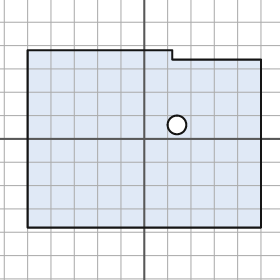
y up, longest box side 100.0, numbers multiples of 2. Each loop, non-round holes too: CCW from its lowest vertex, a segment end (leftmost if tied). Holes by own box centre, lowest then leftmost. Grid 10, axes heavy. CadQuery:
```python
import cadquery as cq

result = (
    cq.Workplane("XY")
    .moveTo(-50.0, -38.0)
    .lineTo(50.0, -38.0)
    .lineTo(50.0, 34.0)
    .lineTo(12.0, 34.0)
    .lineTo(12.0, 38.0)
    .lineTo(-50.0, 38.0)
    .close()
    .moveTo(14.0, 6.0)
    .circle(4.0)
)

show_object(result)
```